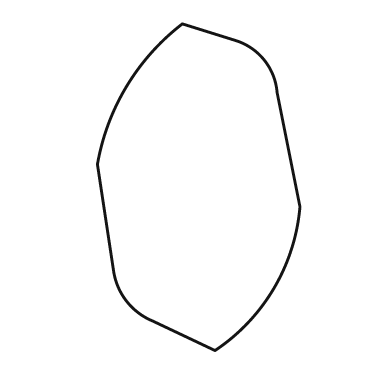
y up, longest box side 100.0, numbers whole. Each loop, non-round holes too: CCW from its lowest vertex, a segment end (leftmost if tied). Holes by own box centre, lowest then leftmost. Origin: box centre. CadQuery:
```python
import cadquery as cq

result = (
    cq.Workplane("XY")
    .moveTo(5.0, -50.0)
    .threePointArc((23.0, -31.0), (31.0, -6.0))
    .lineTo(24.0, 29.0)
    .threePointArc((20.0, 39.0), (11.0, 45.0))
    .lineTo(-5.0, 50.0)
    .threePointArc((-22.0, 31.0), (-31.0, 7.0))
    .lineTo(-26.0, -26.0)
    .threePointArc((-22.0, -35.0), (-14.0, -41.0))
    .close()
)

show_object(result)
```